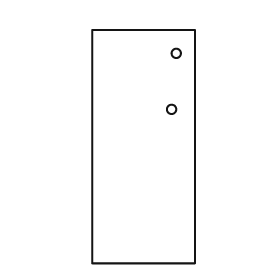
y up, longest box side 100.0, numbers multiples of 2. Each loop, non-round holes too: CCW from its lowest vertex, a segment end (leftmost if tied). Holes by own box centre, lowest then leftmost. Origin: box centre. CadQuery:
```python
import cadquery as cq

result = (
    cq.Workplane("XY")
    .moveTo(-22.0, -50.0)
    .lineTo(22.0, -50.0)
    .lineTo(22.0, 50.0)
    .lineTo(-22.0, 50.0)
    .close()
    .moveTo(12.0, 16.0)
    .circle(2.0)
    .moveTo(14.0, 40.0)
    .circle(2.0)
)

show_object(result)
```